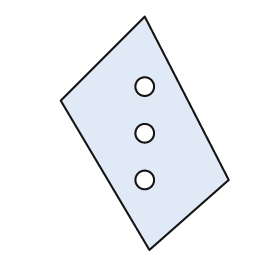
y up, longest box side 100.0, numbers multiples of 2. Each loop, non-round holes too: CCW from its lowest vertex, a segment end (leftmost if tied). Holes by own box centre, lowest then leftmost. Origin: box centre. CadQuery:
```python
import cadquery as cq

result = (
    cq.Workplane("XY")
    .moveTo(2.0, -50.0)
    .lineTo(36.0, -20.0)
    .lineTo(0.0, 50.0)
    .lineTo(-36.0, 14.0)
    .close()
    .moveTo(0.0, -20.0)
    .circle(4.0)
    .moveTo(0.0, 0.0)
    .circle(4.0)
    .moveTo(0.0, 20.0)
    .circle(4.0)
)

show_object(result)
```